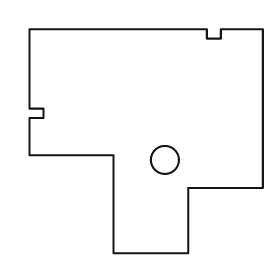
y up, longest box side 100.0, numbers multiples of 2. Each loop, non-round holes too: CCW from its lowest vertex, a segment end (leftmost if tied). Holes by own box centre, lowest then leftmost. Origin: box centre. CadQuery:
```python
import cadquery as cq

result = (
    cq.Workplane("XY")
    .moveTo(-14.0, -48.0)
    .lineTo(18.0, -48.0)
    .lineTo(18.0, -20.0)
    .lineTo(50.0, -20.0)
    .lineTo(50.0, 48.0)
    .lineTo(32.0, 48.0)
    .lineTo(32.0, 44.0)
    .lineTo(26.0, 44.0)
    .lineTo(26.0, 48.0)
    .lineTo(-50.0, 48.0)
    .lineTo(-50.0, 14.0)
    .lineTo(-44.0, 14.0)
    .lineTo(-44.0, 10.0)
    .lineTo(-50.0, 10.0)
    .lineTo(-50.0, -6.0)
    .lineTo(-14.0, -6.0)
    .close()
    .moveTo(8.0, -8.0)
    .circle(6.0)
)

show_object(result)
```